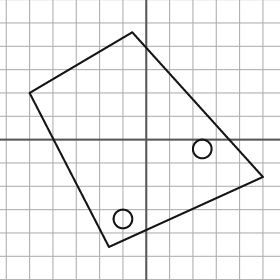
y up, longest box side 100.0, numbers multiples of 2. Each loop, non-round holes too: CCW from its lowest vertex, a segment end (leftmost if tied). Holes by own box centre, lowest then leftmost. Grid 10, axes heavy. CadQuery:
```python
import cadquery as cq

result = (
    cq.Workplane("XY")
    .moveTo(-16.0, -46.0)
    .lineTo(50.0, -16.0)
    .lineTo(-6.0, 46.0)
    .lineTo(-50.0, 20.0)
    .close()
    .moveTo(-10.0, -34.0)
    .circle(4.0)
    .moveTo(24.0, -4.0)
    .circle(4.0)
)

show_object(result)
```